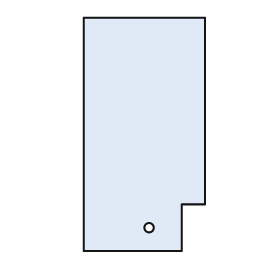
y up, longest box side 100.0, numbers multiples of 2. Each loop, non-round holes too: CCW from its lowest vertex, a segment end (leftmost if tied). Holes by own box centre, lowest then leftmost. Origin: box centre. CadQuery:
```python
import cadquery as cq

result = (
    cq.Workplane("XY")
    .moveTo(-26.0, -50.0)
    .lineTo(16.0, -50.0)
    .lineTo(16.0, -30.0)
    .lineTo(26.0, -30.0)
    .lineTo(26.0, 50.0)
    .lineTo(-26.0, 50.0)
    .close()
    .moveTo(2.0, -40.0)
    .circle(2.0)
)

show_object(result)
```